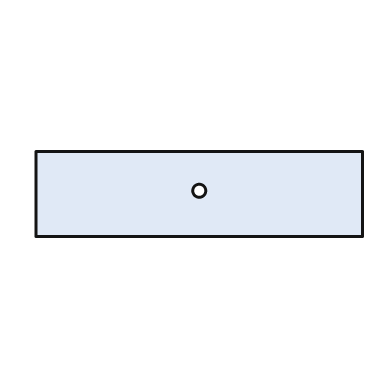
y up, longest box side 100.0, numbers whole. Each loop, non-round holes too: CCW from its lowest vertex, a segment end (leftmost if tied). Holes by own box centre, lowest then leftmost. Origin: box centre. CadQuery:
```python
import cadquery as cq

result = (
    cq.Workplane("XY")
    .moveTo(-50.0, -13.0)
    .lineTo(50.0, -13.0)
    .lineTo(50.0, 13.0)
    .lineTo(-50.0, 13.0)
    .close()
    .moveTo(0.0, 1.0)
    .circle(2.0)
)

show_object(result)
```